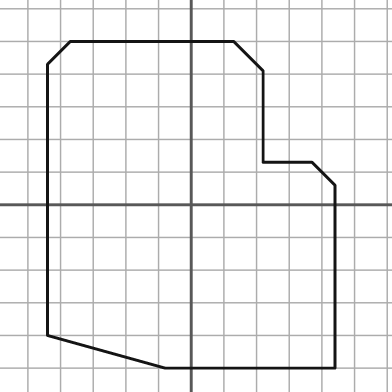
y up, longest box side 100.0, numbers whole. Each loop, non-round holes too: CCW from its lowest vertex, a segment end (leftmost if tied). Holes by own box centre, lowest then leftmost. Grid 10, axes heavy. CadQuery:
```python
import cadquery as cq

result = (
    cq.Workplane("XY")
    .moveTo(-8.0, -50.0)
    .lineTo(44.0, -50.0)
    .lineTo(44.0, 6.0)
    .lineTo(37.0, 13.0)
    .lineTo(22.0, 13.0)
    .lineTo(22.0, 41.0)
    .lineTo(13.0, 50.0)
    .lineTo(-37.0, 50.0)
    .lineTo(-44.0, 43.0)
    .lineTo(-44.0, -40.0)
    .close()
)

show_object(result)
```